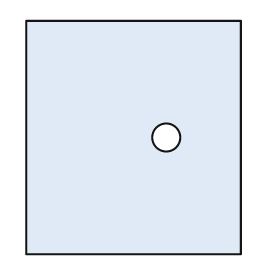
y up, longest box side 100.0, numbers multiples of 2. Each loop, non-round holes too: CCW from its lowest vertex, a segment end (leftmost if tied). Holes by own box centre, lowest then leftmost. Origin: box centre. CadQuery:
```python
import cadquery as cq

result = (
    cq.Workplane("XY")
    .moveTo(-46.0, -50.0)
    .lineTo(46.0, -50.0)
    .lineTo(46.0, 50.0)
    .lineTo(-46.0, 50.0)
    .close()
    .moveTo(14.0, 0.0)
    .circle(6.0)
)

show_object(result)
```